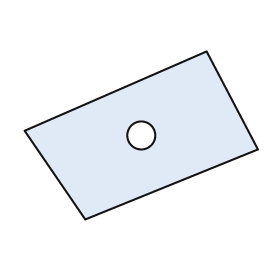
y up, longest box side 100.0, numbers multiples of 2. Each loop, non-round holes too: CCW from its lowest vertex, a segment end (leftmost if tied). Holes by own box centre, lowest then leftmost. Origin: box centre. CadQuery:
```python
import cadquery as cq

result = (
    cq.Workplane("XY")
    .moveTo(-24.0, -36.0)
    .lineTo(50.0, -6.0)
    .lineTo(28.0, 36.0)
    .lineTo(-50.0, 2.0)
    .close()
    .moveTo(0.0, 0.0)
    .circle(6.0)
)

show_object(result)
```